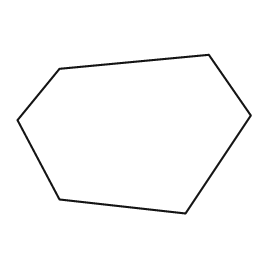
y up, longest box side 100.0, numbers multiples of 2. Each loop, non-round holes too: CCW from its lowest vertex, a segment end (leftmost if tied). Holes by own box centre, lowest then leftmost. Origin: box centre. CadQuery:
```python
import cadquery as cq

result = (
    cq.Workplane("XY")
    .moveTo(22.0, -34.0)
    .lineTo(50.0, 8.0)
    .lineTo(32.0, 34.0)
    .lineTo(-32.0, 28.0)
    .lineTo(-50.0, 6.0)
    .lineTo(-32.0, -28.0)
    .close()
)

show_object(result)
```